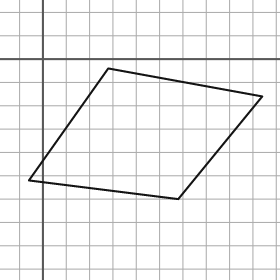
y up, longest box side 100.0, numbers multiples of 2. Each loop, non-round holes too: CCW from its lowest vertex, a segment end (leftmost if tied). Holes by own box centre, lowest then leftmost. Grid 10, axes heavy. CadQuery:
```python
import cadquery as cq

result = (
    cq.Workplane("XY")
    .moveTo(58.0, -60.0)
    .lineTo(94.0, -16.0)
    .lineTo(28.0, -4.0)
    .lineTo(-6.0, -52.0)
    .close()
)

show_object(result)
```